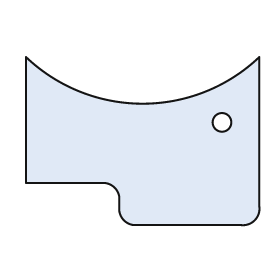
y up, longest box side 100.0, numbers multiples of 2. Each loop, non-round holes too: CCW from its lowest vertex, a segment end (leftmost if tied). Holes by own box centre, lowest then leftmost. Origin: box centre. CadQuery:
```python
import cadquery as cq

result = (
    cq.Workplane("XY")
    .moveTo(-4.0, -36.0)
    .lineTo(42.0, -36.0)
    .threePointArc((48.0, -34.0), (50.0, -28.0))
    .lineTo(50.0, 36.0)
    .threePointArc((0.0, 16.0), (-50.0, 36.0))
    .lineTo(-50.0, -18.0)
    .lineTo(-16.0, -18.0)
    .threePointArc((-12.0, -20.0), (-10.0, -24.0))
    .lineTo(-10.0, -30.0)
    .threePointArc((-8.0, -34.0), (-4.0, -36.0))
    .close()
    .moveTo(34.0, 8.0)
    .circle(4.0)
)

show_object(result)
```